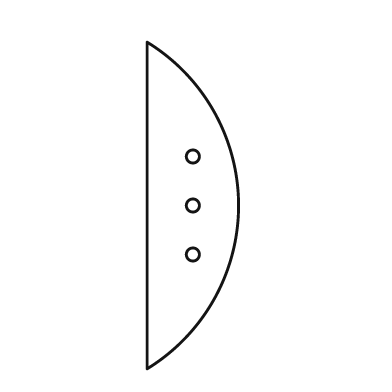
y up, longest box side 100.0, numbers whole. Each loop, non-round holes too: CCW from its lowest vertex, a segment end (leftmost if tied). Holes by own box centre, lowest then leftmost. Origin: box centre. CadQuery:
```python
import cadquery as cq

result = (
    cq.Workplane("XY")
    .moveTo(-14.0, -50.0)
    .threePointArc((14.0, 0.0), (-14.0, 50.0))
    .close()
    .moveTo(0.0, -15.0)
    .circle(2.0)
    .moveTo(0.0, 0.0)
    .circle(2.0)
    .moveTo(0.0, 15.0)
    .circle(2.0)
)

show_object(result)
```